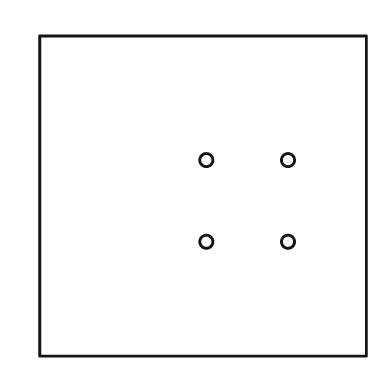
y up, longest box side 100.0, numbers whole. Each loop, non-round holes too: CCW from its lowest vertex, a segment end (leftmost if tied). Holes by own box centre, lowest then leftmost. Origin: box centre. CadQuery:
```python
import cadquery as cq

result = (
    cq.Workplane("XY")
    .moveTo(-50.0, -49.0)
    .lineTo(50.0, -49.0)
    .lineTo(50.0, 49.0)
    .lineTo(-50.0, 49.0)
    .close()
    .moveTo(1.0, -14.0)
    .circle(2.0)
    .moveTo(26.0, -14.0)
    .circle(2.0)
    .moveTo(1.0, 11.0)
    .circle(2.0)
    .moveTo(26.0, 11.0)
    .circle(2.0)
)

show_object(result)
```